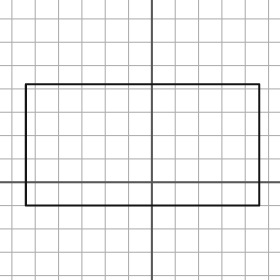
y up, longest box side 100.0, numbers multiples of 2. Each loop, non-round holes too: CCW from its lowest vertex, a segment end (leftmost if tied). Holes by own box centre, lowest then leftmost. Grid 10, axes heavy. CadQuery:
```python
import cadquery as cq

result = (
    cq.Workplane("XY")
    .moveTo(-54.0, -10.0)
    .lineTo(46.0, -10.0)
    .lineTo(46.0, 42.0)
    .lineTo(-54.0, 42.0)
    .close()
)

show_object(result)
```